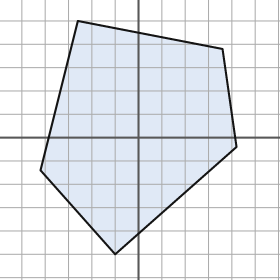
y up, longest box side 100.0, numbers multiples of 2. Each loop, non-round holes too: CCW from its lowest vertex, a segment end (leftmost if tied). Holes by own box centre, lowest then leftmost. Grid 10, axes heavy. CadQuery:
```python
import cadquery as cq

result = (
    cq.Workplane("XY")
    .moveTo(-10.0, -50.0)
    .lineTo(42.0, -4.0)
    .lineTo(36.0, 38.0)
    .lineTo(-26.0, 50.0)
    .lineTo(-42.0, -14.0)
    .close()
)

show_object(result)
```